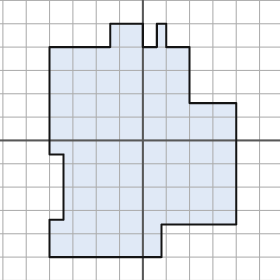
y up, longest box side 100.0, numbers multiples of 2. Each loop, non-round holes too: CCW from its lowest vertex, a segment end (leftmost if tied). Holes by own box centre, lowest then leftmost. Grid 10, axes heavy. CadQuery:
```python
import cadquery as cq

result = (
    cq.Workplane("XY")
    .moveTo(-40.0, -50.0)
    .lineTo(8.0, -50.0)
    .lineTo(8.0, -36.0)
    .lineTo(40.0, -36.0)
    .lineTo(40.0, 16.0)
    .lineTo(20.0, 16.0)
    .lineTo(20.0, 40.0)
    .lineTo(10.0, 40.0)
    .lineTo(10.0, 50.0)
    .lineTo(6.0, 50.0)
    .lineTo(6.0, 40.0)
    .lineTo(0.0, 40.0)
    .lineTo(0.0, 50.0)
    .lineTo(-14.0, 50.0)
    .lineTo(-14.0, 40.0)
    .lineTo(-40.0, 40.0)
    .lineTo(-40.0, -6.0)
    .lineTo(-34.0, -6.0)
    .lineTo(-34.0, -34.0)
    .lineTo(-40.0, -34.0)
    .close()
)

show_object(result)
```